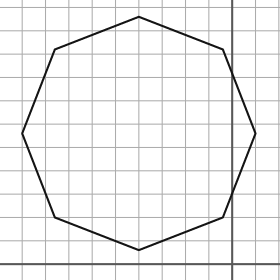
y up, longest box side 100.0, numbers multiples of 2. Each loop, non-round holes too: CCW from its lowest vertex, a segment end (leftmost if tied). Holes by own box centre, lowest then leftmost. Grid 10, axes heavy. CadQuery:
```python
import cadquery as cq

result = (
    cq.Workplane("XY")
    .moveTo(-40.0, 6.0)
    .lineTo(-4.0, 20.0)
    .lineTo(10.0, 56.0)
    .lineTo(-4.0, 92.0)
    .lineTo(-40.0, 106.0)
    .lineTo(-76.0, 92.0)
    .lineTo(-90.0, 56.0)
    .lineTo(-76.0, 20.0)
    .close()
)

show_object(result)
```